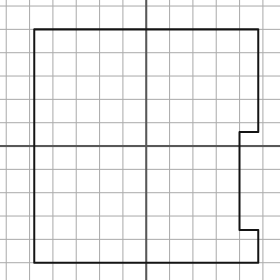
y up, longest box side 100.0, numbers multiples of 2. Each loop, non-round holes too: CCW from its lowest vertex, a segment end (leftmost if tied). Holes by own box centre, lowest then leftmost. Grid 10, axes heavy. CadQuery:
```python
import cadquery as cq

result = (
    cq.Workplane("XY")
    .moveTo(-48.0, -50.0)
    .lineTo(48.0, -50.0)
    .lineTo(48.0, -36.0)
    .lineTo(40.0, -36.0)
    .lineTo(40.0, 6.0)
    .lineTo(48.0, 6.0)
    .lineTo(48.0, 50.0)
    .lineTo(-48.0, 50.0)
    .close()
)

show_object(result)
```